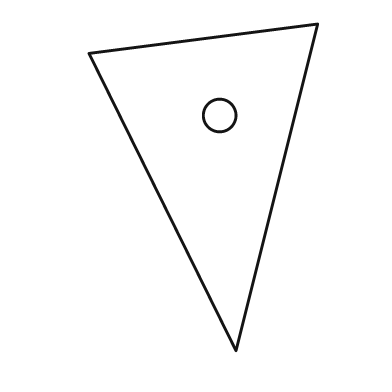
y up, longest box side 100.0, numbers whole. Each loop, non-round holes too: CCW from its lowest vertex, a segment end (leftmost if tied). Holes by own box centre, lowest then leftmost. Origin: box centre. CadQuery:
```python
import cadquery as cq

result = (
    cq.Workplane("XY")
    .moveTo(10.0, -50.0)
    .lineTo(35.0, 50.0)
    .lineTo(-35.0, 41.0)
    .close()
    .moveTo(5.0, 22.0)
    .circle(5.0)
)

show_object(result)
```